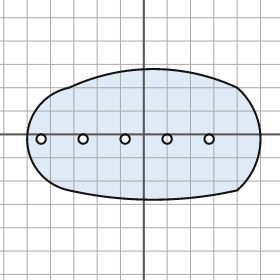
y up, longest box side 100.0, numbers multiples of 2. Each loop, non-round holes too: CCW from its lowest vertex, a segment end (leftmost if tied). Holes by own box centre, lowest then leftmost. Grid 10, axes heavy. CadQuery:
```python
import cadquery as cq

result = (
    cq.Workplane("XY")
    .moveTo(-32.0, -24.0)
    .threePointArc((4.0, -28.0), (40.0, -24.0))
    .threePointArc((50.0, -2.0), (40.0, 20.0))
    .threePointArc((4.0, 28.0), (-32.0, 20.0))
    .threePointArc((-50.0, -2.0), (-32.0, -24.0))
    .close()
    .moveTo(-44.0, -2.0)
    .circle(2.0)
    .moveTo(-26.0, -2.0)
    .circle(2.0)
    .moveTo(-8.0, -2.0)
    .circle(2.0)
    .moveTo(10.0, -2.0)
    .circle(2.0)
    .moveTo(28.0, -2.0)
    .circle(2.0)
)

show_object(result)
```